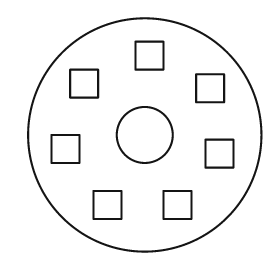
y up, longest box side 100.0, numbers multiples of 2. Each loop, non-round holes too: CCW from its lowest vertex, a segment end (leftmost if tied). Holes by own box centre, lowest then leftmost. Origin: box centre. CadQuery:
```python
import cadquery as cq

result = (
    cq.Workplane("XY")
    .moveTo(0.0, 0.0)
    .circle(50.0)
    .moveTo(-22.0, -36.0)
    .lineTo(-10.0, -36.0)
    .lineTo(-10.0, -24.0)
    .lineTo(-22.0, -24.0)
    .close()
    .moveTo(8.0, -36.0)
    .lineTo(20.0, -36.0)
    .lineTo(20.0, -24.0)
    .lineTo(8.0, -24.0)
    .close()
    .moveTo(26.0, -14.0)
    .lineTo(38.0, -14.0)
    .lineTo(38.0, -2.0)
    .lineTo(26.0, -2.0)
    .close()
    .moveTo(-40.0, -12.0)
    .lineTo(-28.0, -12.0)
    .lineTo(-28.0, 0.0)
    .lineTo(-40.0, 0.0)
    .close()
    .moveTo(0.0, 0.0)
    .circle(12.0)
    .moveTo(22.0, 14.0)
    .lineTo(34.0, 14.0)
    .lineTo(34.0, 26.0)
    .lineTo(22.0, 26.0)
    .close()
    .moveTo(-32.0, 16.0)
    .lineTo(-20.0, 16.0)
    .lineTo(-20.0, 28.0)
    .lineTo(-32.0, 28.0)
    .close()
    .moveTo(-4.0, 28.0)
    .lineTo(8.0, 28.0)
    .lineTo(8.0, 40.0)
    .lineTo(-4.0, 40.0)
    .close()
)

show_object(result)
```